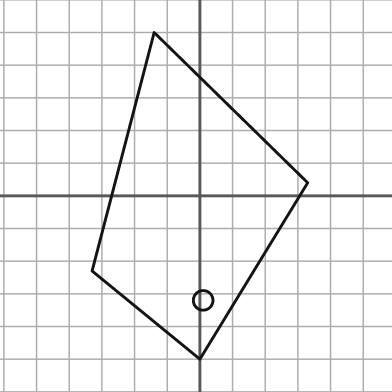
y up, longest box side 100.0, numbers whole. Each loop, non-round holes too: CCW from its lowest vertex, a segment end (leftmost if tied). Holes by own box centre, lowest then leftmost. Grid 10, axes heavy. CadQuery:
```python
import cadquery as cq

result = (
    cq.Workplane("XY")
    .moveTo(0.0, -50.0)
    .lineTo(33.0, 4.0)
    .lineTo(-14.0, 50.0)
    .lineTo(-33.0, -23.0)
    .close()
    .moveTo(1.0, -32.0)
    .circle(3.0)
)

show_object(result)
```